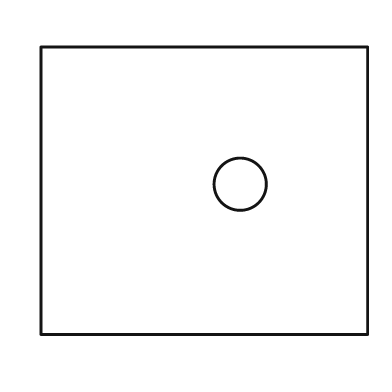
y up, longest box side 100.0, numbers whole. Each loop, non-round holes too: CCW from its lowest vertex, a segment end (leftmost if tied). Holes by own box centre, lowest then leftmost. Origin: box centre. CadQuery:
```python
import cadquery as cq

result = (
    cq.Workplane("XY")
    .moveTo(-50.0, -44.0)
    .lineTo(50.0, -44.0)
    .lineTo(50.0, 44.0)
    .lineTo(-50.0, 44.0)
    .close()
    .moveTo(11.0, 2.0)
    .circle(8.0)
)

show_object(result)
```